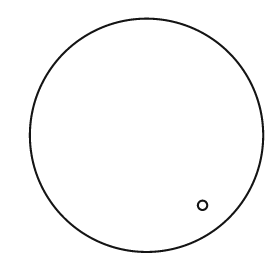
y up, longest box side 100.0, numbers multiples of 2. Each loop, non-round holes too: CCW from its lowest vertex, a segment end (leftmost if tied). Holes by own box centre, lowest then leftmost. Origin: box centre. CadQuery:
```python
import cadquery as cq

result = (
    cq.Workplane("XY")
    .moveTo(0.0, 0.0)
    .circle(50.0)
    .moveTo(24.0, -30.0)
    .circle(2.0)
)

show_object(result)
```